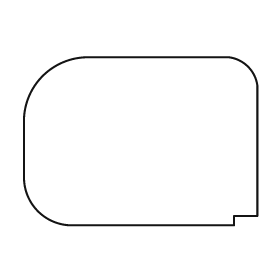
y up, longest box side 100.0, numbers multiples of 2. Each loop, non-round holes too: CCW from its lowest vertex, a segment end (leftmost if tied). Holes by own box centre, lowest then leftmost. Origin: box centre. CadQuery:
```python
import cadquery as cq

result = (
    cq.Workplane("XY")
    .moveTo(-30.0, -36.0)
    .lineTo(40.0, -36.0)
    .lineTo(40.0, -32.0)
    .lineTo(50.0, -32.0)
    .lineTo(50.0, 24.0)
    .threePointArc((46.0, 32.0), (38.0, 36.0))
    .lineTo(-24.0, 36.0)
    .threePointArc((-42.0, 28.0), (-50.0, 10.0))
    .lineTo(-50.0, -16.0)
    .threePointArc((-44.0, -30.0), (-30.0, -36.0))
    .close()
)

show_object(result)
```